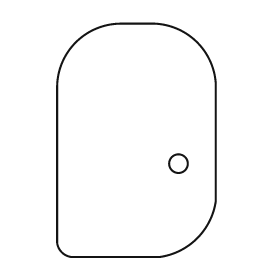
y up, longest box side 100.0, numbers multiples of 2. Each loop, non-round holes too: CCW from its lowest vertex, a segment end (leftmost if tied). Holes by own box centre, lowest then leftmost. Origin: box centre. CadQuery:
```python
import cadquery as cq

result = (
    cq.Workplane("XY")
    .moveTo(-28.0, -50.0)
    .lineTo(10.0, -50.0)
    .threePointArc((26.0, -42.0), (34.0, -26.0))
    .lineTo(34.0, 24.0)
    .threePointArc((26.0, 42.0), (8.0, 50.0))
    .lineTo(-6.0, 50.0)
    .threePointArc((-26.0, 42.0), (-34.0, 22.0))
    .lineTo(-34.0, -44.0)
    .threePointArc((-32.0, -48.0), (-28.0, -50.0))
    .close()
    .moveTo(18.0, -10.0)
    .circle(4.0)
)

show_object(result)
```